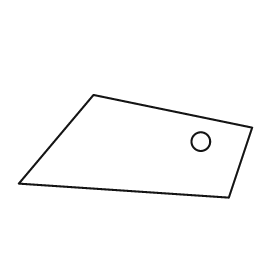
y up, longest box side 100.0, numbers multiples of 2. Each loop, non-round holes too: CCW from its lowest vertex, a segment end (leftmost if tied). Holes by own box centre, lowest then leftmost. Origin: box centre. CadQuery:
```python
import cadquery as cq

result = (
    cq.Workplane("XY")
    .moveTo(40.0, -22.0)
    .lineTo(50.0, 8.0)
    .lineTo(-18.0, 22.0)
    .lineTo(-50.0, -16.0)
    .close()
    .moveTo(28.0, 2.0)
    .circle(4.0)
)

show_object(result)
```